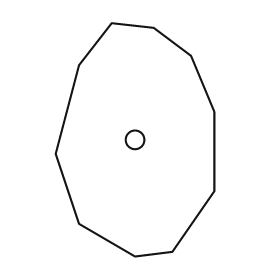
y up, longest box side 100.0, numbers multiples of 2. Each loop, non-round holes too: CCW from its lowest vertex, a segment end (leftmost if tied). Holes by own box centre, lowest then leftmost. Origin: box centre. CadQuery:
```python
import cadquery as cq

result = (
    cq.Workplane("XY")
    .moveTo(0.0, -50.0)
    .lineTo(16.0, -48.0)
    .lineTo(34.0, -22.0)
    .lineTo(34.0, 12.0)
    .lineTo(24.0, 36.0)
    .lineTo(8.0, 48.0)
    .lineTo(-10.0, 50.0)
    .lineTo(-24.0, 32.0)
    .lineTo(-34.0, -6.0)
    .lineTo(-24.0, -36.0)
    .close()
    .moveTo(0.0, 0.0)
    .circle(4.0)
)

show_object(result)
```